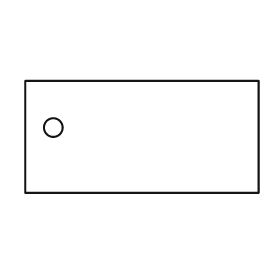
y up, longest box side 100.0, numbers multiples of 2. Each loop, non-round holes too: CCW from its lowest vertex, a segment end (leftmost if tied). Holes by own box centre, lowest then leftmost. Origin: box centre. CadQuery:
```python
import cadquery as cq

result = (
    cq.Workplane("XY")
    .moveTo(-50.0, -24.0)
    .lineTo(50.0, -24.0)
    .lineTo(50.0, 24.0)
    .lineTo(-50.0, 24.0)
    .close()
    .moveTo(-38.0, 4.0)
    .circle(4.0)
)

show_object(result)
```